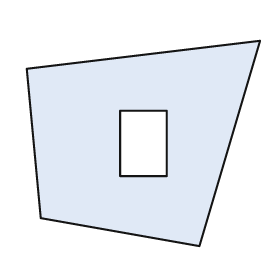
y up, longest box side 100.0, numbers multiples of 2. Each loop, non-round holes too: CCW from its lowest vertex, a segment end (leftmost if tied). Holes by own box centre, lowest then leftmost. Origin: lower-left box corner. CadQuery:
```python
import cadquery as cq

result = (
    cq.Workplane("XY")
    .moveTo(74.0, 0.0)
    .lineTo(100.0, 88.0)
    .lineTo(0.0, 76.0)
    .lineTo(6.0, 12.0)
    .close()
    .moveTo(40.0, 30.0)
    .lineTo(60.0, 30.0)
    .lineTo(60.0, 58.0)
    .lineTo(40.0, 58.0)
    .close()
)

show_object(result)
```